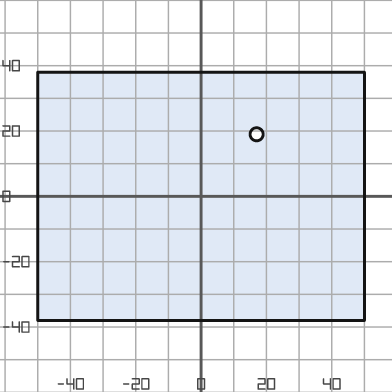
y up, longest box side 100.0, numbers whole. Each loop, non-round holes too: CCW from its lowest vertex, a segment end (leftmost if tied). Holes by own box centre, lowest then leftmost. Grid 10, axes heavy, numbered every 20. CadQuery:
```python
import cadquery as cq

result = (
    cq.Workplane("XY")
    .moveTo(-50.0, -38.0)
    .lineTo(50.0, -38.0)
    .lineTo(50.0, 38.0)
    .lineTo(-50.0, 38.0)
    .close()
    .moveTo(17.0, 19.0)
    .circle(2.0)
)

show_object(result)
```